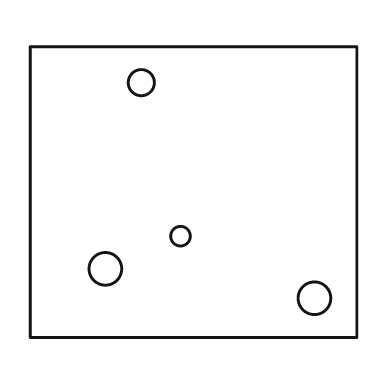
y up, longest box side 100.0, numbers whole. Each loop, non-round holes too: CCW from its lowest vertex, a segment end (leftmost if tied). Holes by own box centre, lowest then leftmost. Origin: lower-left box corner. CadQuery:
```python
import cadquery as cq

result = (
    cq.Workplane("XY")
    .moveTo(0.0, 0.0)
    .lineTo(100.0, 0.0)
    .lineTo(100.0, 89.0)
    .lineTo(0.0, 89.0)
    .close()
    .moveTo(87.0, 12.0)
    .circle(5.0)
    .moveTo(23.0, 21.0)
    .circle(5.0)
    .moveTo(46.0, 31.0)
    .circle(3.0)
    .moveTo(34.0, 78.0)
    .circle(4.0)
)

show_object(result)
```